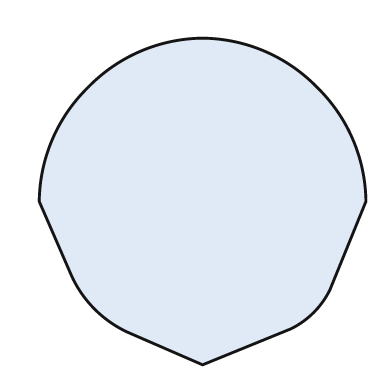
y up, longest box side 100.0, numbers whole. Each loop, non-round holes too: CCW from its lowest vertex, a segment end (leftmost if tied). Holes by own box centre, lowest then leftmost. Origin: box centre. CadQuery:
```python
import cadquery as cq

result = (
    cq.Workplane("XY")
    .moveTo(0.0, -50.0)
    .lineTo(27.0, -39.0)
    .threePointArc((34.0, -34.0), (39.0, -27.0))
    .lineTo(50.0, 0.0)
    .threePointArc((46.0, 19.0), (35.0, 35.0))
    .threePointArc((19.0, 46.0), (0.0, 50.0))
    .threePointArc((-19.0, 46.0), (-35.0, 35.0))
    .threePointArc((-46.0, 19.0), (-50.0, 0.0))
    .lineTo(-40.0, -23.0)
    .threePointArc((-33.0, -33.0), (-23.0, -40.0))
    .close()
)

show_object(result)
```